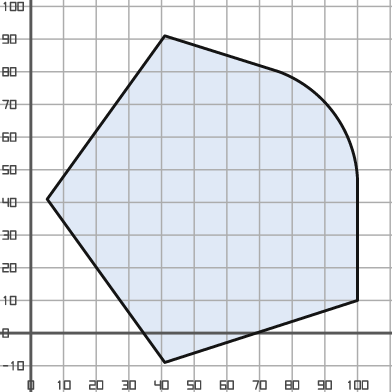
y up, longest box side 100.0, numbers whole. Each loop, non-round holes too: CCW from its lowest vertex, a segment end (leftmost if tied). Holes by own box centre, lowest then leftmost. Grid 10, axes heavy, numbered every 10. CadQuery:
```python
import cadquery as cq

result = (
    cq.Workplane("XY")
    .moveTo(41.0, -9.0)
    .lineTo(100.0, 10.0)
    .lineTo(100.0, 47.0)
    .threePointArc((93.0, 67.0), (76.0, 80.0))
    .lineTo(41.0, 91.0)
    .lineTo(5.0, 41.0)
    .close()
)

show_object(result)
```